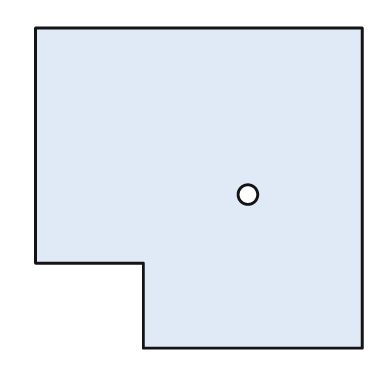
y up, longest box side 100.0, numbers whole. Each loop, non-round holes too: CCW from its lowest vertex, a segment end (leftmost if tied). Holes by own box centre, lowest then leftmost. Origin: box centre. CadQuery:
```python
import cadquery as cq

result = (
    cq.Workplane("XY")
    .moveTo(-17.0, -49.0)
    .lineTo(50.0, -49.0)
    .lineTo(50.0, 49.0)
    .lineTo(-50.0, 49.0)
    .lineTo(-50.0, -23.0)
    .lineTo(-17.0, -23.0)
    .close()
    .moveTo(15.0, -2.0)
    .circle(3.0)
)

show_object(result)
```